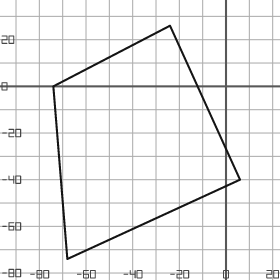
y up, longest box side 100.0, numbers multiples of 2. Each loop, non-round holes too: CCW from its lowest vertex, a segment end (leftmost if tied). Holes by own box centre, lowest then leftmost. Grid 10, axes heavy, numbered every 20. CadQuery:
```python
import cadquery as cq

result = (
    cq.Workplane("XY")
    .moveTo(-68.0, -74.0)
    .lineTo(6.0, -40.0)
    .lineTo(-24.0, 26.0)
    .lineTo(-74.0, 0.0)
    .close()
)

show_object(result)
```